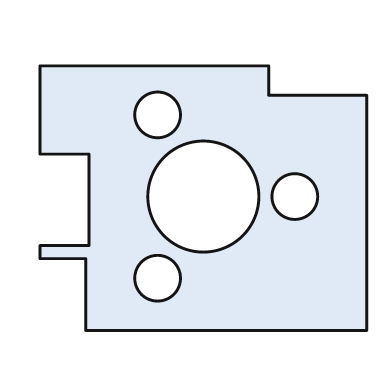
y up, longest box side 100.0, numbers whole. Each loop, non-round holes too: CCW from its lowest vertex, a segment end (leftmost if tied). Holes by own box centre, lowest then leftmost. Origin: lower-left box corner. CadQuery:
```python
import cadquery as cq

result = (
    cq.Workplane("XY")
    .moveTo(14.0, 0.0)
    .lineTo(100.0, 0.0)
    .lineTo(100.0, 72.0)
    .lineTo(70.0, 72.0)
    .lineTo(70.0, 81.0)
    .lineTo(0.0, 81.0)
    .lineTo(0.0, 54.0)
    .lineTo(15.0, 54.0)
    .lineTo(15.0, 26.0)
    .lineTo(0.0, 26.0)
    .lineTo(0.0, 22.0)
    .lineTo(14.0, 22.0)
    .close()
    .moveTo(36.0, 16.0)
    .circle(7.0)
    .moveTo(50.0, 41.0)
    .circle(17.0)
    .moveTo(78.0, 41.0)
    .circle(7.0)
    .moveTo(36.0, 66.0)
    .circle(7.0)
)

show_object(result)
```